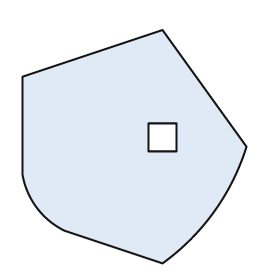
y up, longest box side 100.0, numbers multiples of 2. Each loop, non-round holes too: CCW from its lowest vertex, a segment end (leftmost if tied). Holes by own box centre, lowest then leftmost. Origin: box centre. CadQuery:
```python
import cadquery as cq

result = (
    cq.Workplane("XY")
    .moveTo(12.0, -50.0)
    .threePointArc((34.0, -28.0), (48.0, 0.0))
    .lineTo(12.0, 50.0)
    .lineTo(-48.0, 30.0)
    .lineTo(-48.0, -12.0)
    .threePointArc((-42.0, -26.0), (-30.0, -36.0))
    .close()
    .moveTo(6.0, -2.0)
    .lineTo(18.0, -2.0)
    .lineTo(18.0, 10.0)
    .lineTo(6.0, 10.0)
    .close()
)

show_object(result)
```